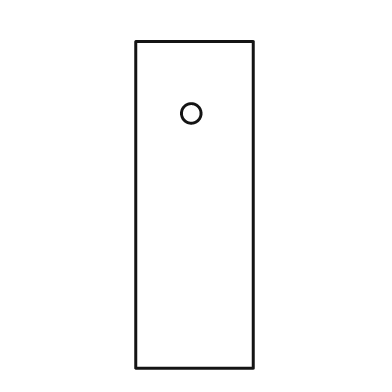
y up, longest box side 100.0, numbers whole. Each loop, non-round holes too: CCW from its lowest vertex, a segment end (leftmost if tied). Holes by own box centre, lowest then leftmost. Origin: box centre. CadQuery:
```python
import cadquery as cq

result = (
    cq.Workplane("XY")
    .moveTo(-18.0, -50.0)
    .lineTo(18.0, -50.0)
    .lineTo(18.0, 50.0)
    .lineTo(-18.0, 50.0)
    .close()
    .moveTo(-1.0, 28.0)
    .circle(3.0)
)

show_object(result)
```